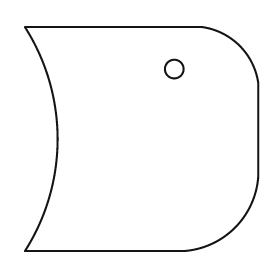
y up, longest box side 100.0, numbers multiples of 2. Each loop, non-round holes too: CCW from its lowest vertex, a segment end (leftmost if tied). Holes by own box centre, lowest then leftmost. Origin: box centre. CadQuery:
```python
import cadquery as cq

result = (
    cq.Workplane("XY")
    .moveTo(-50.0, -48.0)
    .lineTo(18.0, -48.0)
    .threePointArc((40.0, -38.0), (50.0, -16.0))
    .lineTo(50.0, 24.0)
    .threePointArc((42.0, 40.0), (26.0, 48.0))
    .lineTo(-50.0, 48.0)
    .threePointArc((-36.0, 0.0), (-50.0, -48.0))
    .close()
    .moveTo(14.0, 30.0)
    .circle(4.0)
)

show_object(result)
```